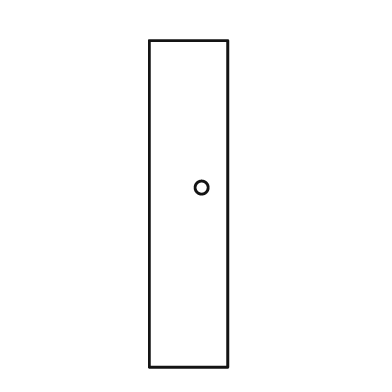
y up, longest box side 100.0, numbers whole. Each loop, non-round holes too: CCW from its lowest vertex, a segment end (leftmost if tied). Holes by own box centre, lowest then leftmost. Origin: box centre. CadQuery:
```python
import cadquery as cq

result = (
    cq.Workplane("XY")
    .moveTo(-12.0, -50.0)
    .lineTo(12.0, -50.0)
    .lineTo(12.0, 50.0)
    .lineTo(-12.0, 50.0)
    .close()
    .moveTo(4.0, 5.0)
    .circle(2.0)
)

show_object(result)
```